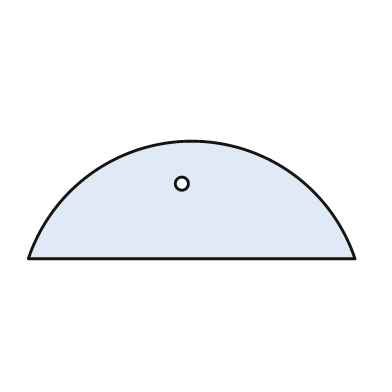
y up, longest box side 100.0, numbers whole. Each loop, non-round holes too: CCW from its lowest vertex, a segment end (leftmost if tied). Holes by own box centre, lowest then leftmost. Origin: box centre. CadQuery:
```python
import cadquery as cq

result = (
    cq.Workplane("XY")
    .moveTo(-50.0, -18.0)
    .lineTo(50.0, -18.0)
    .threePointArc((0.0, 18.0), (-50.0, -18.0))
    .close()
    .moveTo(-3.0, 5.0)
    .circle(2.0)
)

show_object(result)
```